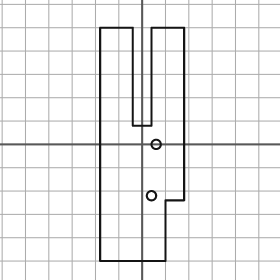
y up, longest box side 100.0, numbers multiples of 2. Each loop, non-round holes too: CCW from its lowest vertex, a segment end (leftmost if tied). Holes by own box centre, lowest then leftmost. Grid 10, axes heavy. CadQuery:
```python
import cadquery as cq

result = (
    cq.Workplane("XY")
    .moveTo(-18.0, -50.0)
    .lineTo(10.0, -50.0)
    .lineTo(10.0, -24.0)
    .lineTo(18.0, -24.0)
    .lineTo(18.0, 50.0)
    .lineTo(4.0, 50.0)
    .lineTo(4.0, 8.0)
    .lineTo(-4.0, 8.0)
    .lineTo(-4.0, 50.0)
    .lineTo(-18.0, 50.0)
    .close()
    .moveTo(4.0, -22.0)
    .circle(2.0)
    .moveTo(6.0, 0.0)
    .circle(2.0)
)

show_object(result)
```